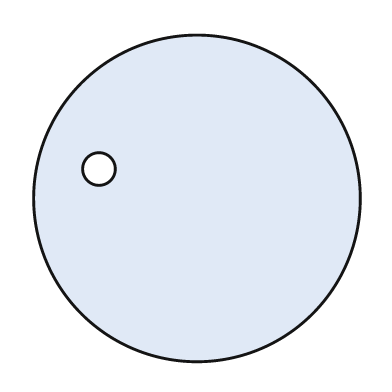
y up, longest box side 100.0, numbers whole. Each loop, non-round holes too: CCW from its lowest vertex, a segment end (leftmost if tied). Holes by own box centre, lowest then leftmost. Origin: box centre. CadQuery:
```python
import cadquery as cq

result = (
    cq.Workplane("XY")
    .moveTo(0.0, 0.0)
    .circle(50.0)
    .moveTo(-30.0, 9.0)
    .circle(5.0)
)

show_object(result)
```